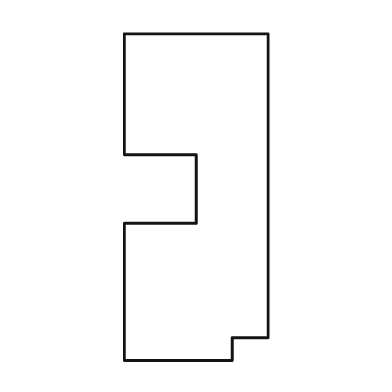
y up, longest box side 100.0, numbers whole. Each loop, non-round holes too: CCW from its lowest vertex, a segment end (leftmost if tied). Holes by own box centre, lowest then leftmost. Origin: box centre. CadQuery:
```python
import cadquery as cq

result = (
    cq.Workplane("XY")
    .moveTo(-22.0, -50.0)
    .lineTo(11.0, -50.0)
    .lineTo(11.0, -43.0)
    .lineTo(22.0, -43.0)
    .lineTo(22.0, 50.0)
    .lineTo(-22.0, 50.0)
    .lineTo(-22.0, 13.0)
    .lineTo(0.0, 13.0)
    .lineTo(0.0, -8.0)
    .lineTo(-22.0, -8.0)
    .close()
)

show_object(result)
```